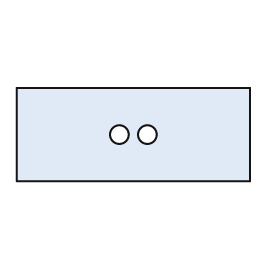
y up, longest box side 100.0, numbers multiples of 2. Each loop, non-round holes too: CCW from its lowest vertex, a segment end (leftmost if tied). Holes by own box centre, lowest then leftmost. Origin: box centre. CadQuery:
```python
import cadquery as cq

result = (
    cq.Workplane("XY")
    .moveTo(-50.0, -20.0)
    .lineTo(50.0, -20.0)
    .lineTo(50.0, 20.0)
    .lineTo(-50.0, 20.0)
    .close()
    .moveTo(-6.0, 0.0)
    .circle(4.0)
    .moveTo(6.0, 0.0)
    .circle(4.0)
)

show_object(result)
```